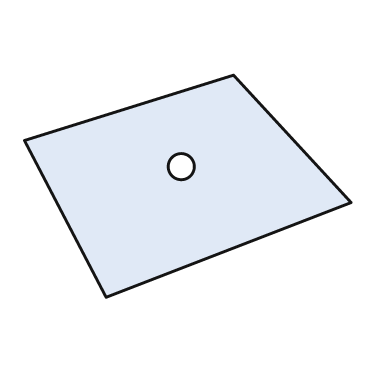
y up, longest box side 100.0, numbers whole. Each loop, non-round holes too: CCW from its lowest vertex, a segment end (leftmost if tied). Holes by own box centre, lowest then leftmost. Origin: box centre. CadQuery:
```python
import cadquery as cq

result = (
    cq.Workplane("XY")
    .moveTo(-25.0, -34.0)
    .lineTo(50.0, -5.0)
    .lineTo(14.0, 34.0)
    .lineTo(-50.0, 14.0)
    .close()
    .moveTo(-2.0, 6.0)
    .circle(4.0)
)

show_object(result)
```